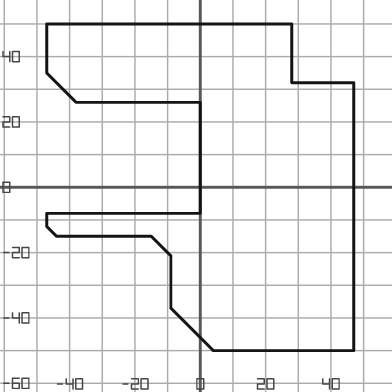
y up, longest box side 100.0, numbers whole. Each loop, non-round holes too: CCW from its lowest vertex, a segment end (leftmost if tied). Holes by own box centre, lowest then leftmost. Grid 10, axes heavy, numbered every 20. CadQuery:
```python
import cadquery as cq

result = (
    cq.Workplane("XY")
    .moveTo(4.0, -50.0)
    .lineTo(47.0, -50.0)
    .lineTo(47.0, 32.0)
    .lineTo(28.0, 32.0)
    .lineTo(28.0, 50.0)
    .lineTo(-47.0, 50.0)
    .lineTo(-47.0, 35.0)
    .lineTo(-38.0, 26.0)
    .lineTo(0.0, 26.0)
    .lineTo(0.0, -8.0)
    .lineTo(-47.0, -8.0)
    .lineTo(-47.0, -12.0)
    .lineTo(-44.0, -15.0)
    .lineTo(-15.0, -15.0)
    .lineTo(-9.0, -21.0)
    .lineTo(-9.0, -37.0)
    .close()
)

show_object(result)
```